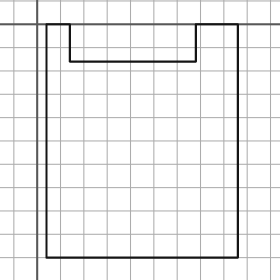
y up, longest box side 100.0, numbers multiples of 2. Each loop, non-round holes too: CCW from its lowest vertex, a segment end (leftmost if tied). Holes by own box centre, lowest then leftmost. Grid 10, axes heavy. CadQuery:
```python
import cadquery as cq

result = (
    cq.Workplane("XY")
    .moveTo(4.0, -100.0)
    .lineTo(86.0, -100.0)
    .lineTo(86.0, 0.0)
    .lineTo(68.0, 0.0)
    .lineTo(68.0, -16.0)
    .lineTo(14.0, -16.0)
    .lineTo(14.0, 0.0)
    .lineTo(4.0, 0.0)
    .close()
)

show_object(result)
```